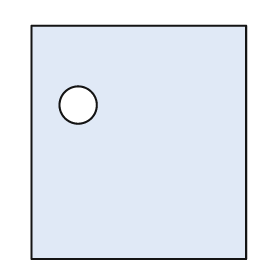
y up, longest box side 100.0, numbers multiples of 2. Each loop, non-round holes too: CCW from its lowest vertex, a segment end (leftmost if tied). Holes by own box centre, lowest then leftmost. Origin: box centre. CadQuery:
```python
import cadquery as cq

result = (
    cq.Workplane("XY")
    .moveTo(-46.0, -50.0)
    .lineTo(46.0, -50.0)
    .lineTo(46.0, 50.0)
    .lineTo(-46.0, 50.0)
    .close()
    .moveTo(-26.0, 16.0)
    .circle(8.0)
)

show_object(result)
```